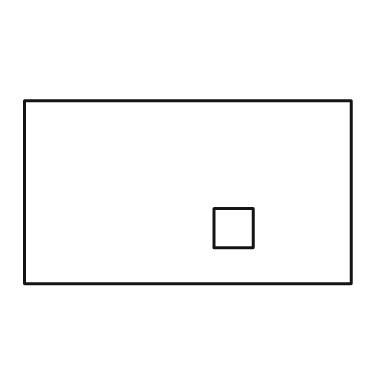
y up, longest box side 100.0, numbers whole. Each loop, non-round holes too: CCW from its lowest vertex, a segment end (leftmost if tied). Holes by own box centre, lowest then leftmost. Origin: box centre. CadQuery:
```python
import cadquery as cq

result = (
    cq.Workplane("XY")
    .moveTo(-50.0, -28.0)
    .lineTo(50.0, -28.0)
    .lineTo(50.0, 28.0)
    .lineTo(-50.0, 28.0)
    .close()
    .moveTo(8.0, -17.0)
    .lineTo(20.0, -17.0)
    .lineTo(20.0, -5.0)
    .lineTo(8.0, -5.0)
    .close()
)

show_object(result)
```